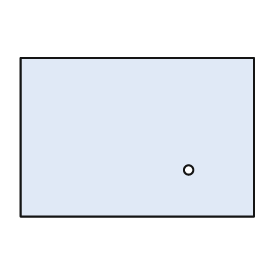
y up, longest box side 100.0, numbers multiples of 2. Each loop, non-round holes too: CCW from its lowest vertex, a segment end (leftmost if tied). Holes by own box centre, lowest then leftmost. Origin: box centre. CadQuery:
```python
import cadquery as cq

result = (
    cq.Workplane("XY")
    .moveTo(-50.0, -34.0)
    .lineTo(50.0, -34.0)
    .lineTo(50.0, 34.0)
    .lineTo(-50.0, 34.0)
    .close()
    .moveTo(22.0, -14.0)
    .circle(2.0)
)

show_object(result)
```